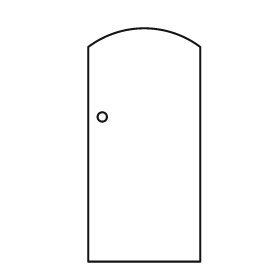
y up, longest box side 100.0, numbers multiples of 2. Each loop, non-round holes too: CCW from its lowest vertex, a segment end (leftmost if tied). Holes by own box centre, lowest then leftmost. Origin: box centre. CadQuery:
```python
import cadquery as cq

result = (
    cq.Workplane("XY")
    .moveTo(-24.0, -50.0)
    .lineTo(24.0, -50.0)
    .lineTo(24.0, 42.0)
    .threePointArc((0.0, 50.0), (-24.0, 42.0))
    .close()
    .moveTo(-18.0, 12.0)
    .circle(2.0)
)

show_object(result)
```